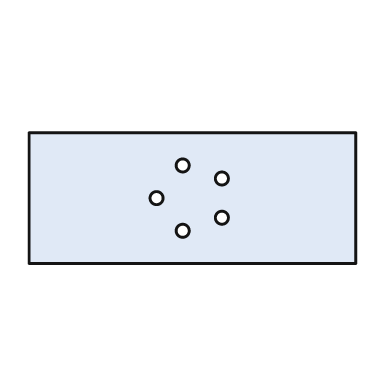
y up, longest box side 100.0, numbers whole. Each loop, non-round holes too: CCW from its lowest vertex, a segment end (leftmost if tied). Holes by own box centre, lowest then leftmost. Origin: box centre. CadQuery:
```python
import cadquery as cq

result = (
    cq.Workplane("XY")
    .moveTo(-50.0, -20.0)
    .lineTo(50.0, -20.0)
    .lineTo(50.0, 20.0)
    .lineTo(-50.0, 20.0)
    .close()
    .moveTo(-3.0, -10.0)
    .circle(2.0)
    .moveTo(9.0, -6.0)
    .circle(2.0)
    .moveTo(-11.0, 0.0)
    .circle(2.0)
    .moveTo(9.0, 6.0)
    .circle(2.0)
    .moveTo(-3.0, 10.0)
    .circle(2.0)
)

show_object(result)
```